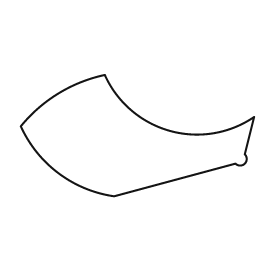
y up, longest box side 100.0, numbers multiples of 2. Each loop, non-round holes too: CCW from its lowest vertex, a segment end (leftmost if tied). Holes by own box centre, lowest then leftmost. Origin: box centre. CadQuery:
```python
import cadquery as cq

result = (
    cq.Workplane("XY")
    .moveTo(-10.0, -26.0)
    .lineTo(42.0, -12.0)
    .threePointArc((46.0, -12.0), (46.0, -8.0))
    .lineTo(50.0, 8.0)
    .threePointArc((14.0, 2.0), (-14.0, 26.0))
    .threePointArc((-34.0, 18.0), (-50.0, 4.0))
    .threePointArc((-34.0, -16.0), (-10.0, -26.0))
    .close()
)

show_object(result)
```